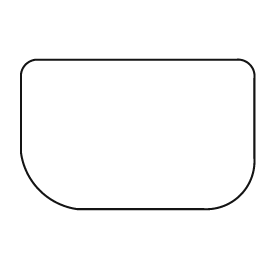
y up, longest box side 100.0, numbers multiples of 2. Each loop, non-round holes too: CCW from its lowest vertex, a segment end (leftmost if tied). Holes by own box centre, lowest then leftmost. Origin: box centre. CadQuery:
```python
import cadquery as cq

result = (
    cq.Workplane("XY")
    .moveTo(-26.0, -32.0)
    .lineTo(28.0, -32.0)
    .threePointArc((44.0, -26.0), (50.0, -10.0))
    .lineTo(50.0, 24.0)
    .threePointArc((48.0, 30.0), (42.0, 32.0))
    .lineTo(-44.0, 32.0)
    .threePointArc((-48.0, 30.0), (-50.0, 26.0))
    .lineTo(-50.0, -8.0)
    .threePointArc((-42.0, -24.0), (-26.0, -32.0))
    .close()
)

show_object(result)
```